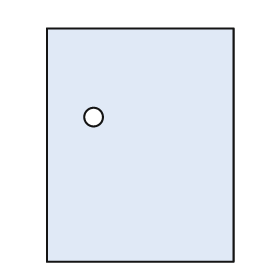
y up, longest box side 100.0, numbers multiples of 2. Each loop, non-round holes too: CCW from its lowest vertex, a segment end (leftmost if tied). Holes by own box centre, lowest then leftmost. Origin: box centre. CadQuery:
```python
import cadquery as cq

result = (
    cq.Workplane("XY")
    .moveTo(-40.0, -50.0)
    .lineTo(40.0, -50.0)
    .lineTo(40.0, 50.0)
    .lineTo(-40.0, 50.0)
    .close()
    .moveTo(-20.0, 12.0)
    .circle(4.0)
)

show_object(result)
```